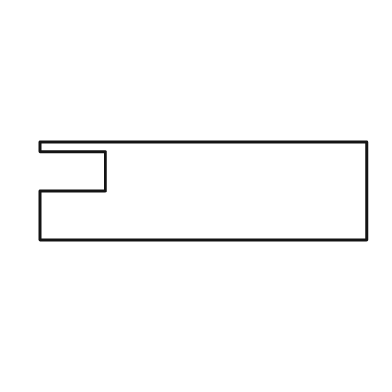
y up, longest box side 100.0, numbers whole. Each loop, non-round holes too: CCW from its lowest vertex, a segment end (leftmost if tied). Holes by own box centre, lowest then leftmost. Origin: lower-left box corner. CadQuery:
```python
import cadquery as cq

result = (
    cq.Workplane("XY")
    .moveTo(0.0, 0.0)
    .lineTo(100.0, 0.0)
    .lineTo(100.0, 30.0)
    .lineTo(0.0, 30.0)
    .lineTo(0.0, 27.0)
    .lineTo(20.0, 27.0)
    .lineTo(20.0, 15.0)
    .lineTo(0.0, 15.0)
    .close()
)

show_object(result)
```